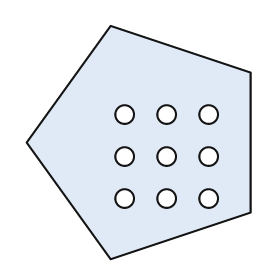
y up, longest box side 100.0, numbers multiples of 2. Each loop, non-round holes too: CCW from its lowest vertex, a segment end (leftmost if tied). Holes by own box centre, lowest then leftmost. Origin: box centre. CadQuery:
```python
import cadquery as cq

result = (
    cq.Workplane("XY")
    .moveTo(-12.0, -50.0)
    .lineTo(48.0, -30.0)
    .lineTo(48.0, 30.0)
    .lineTo(-12.0, 50.0)
    .lineTo(-48.0, 0.0)
    .close()
    .moveTo(-6.0, -24.0)
    .circle(4.0)
    .moveTo(12.0, -24.0)
    .circle(4.0)
    .moveTo(30.0, -24.0)
    .circle(4.0)
    .moveTo(-6.0, -6.0)
    .circle(4.0)
    .moveTo(12.0, -6.0)
    .circle(4.0)
    .moveTo(30.0, -6.0)
    .circle(4.0)
    .moveTo(-6.0, 12.0)
    .circle(4.0)
    .moveTo(12.0, 12.0)
    .circle(4.0)
    .moveTo(30.0, 12.0)
    .circle(4.0)
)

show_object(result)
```